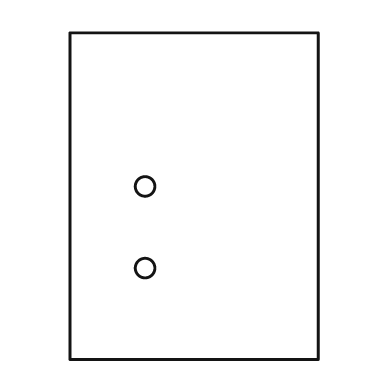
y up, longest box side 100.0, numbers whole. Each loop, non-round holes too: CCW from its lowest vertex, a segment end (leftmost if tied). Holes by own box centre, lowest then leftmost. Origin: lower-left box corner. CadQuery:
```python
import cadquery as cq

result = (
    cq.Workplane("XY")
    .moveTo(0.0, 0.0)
    .lineTo(76.0, 0.0)
    .lineTo(76.0, 100.0)
    .lineTo(0.0, 100.0)
    .close()
    .moveTo(23.0, 28.0)
    .circle(3.0)
    .moveTo(23.0, 53.0)
    .circle(3.0)
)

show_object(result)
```